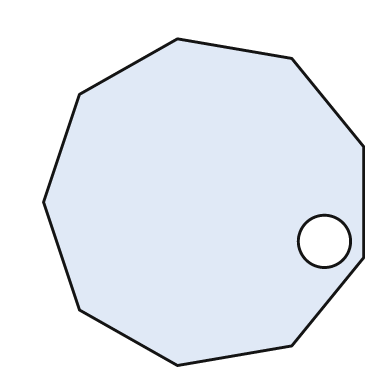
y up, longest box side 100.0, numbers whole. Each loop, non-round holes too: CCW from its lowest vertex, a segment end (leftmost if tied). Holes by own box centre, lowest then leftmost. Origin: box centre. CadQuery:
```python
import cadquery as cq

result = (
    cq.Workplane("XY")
    .moveTo(-8.0, -50.0)
    .lineTo(27.0, -44.0)
    .lineTo(49.0, -17.0)
    .lineTo(49.0, 17.0)
    .lineTo(27.0, 44.0)
    .lineTo(-8.0, 50.0)
    .lineTo(-38.0, 33.0)
    .lineTo(-49.0, 0.0)
    .lineTo(-38.0, -33.0)
    .close()
    .moveTo(37.0, -12.0)
    .circle(8.0)
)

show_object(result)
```